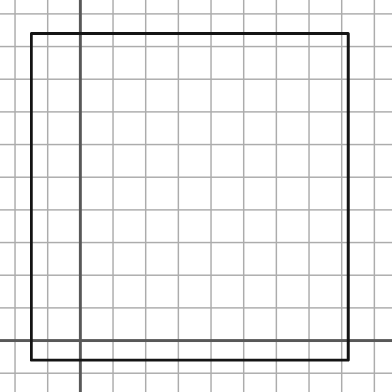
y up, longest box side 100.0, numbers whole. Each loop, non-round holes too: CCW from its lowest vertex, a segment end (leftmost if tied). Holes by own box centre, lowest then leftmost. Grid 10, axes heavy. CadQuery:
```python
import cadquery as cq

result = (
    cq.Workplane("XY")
    .moveTo(-15.0, -6.0)
    .lineTo(82.0, -6.0)
    .lineTo(82.0, 94.0)
    .lineTo(-15.0, 94.0)
    .close()
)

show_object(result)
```